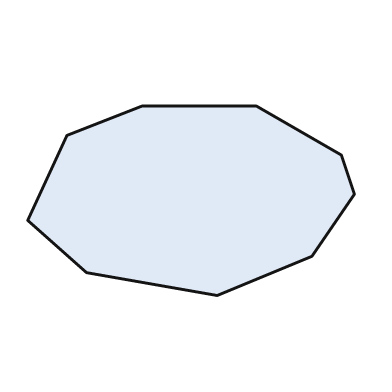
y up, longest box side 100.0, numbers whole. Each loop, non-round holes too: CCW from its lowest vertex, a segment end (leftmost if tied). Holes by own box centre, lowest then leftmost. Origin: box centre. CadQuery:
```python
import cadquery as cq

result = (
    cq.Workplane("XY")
    .moveTo(8.0, -29.0)
    .lineTo(37.0, -17.0)
    .lineTo(50.0, 2.0)
    .lineTo(46.0, 14.0)
    .lineTo(20.0, 29.0)
    .lineTo(-15.0, 29.0)
    .lineTo(-38.0, 20.0)
    .lineTo(-50.0, -6.0)
    .lineTo(-32.0, -22.0)
    .close()
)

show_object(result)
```